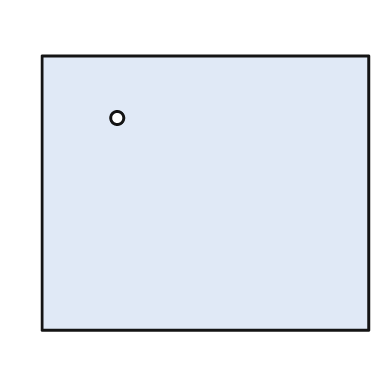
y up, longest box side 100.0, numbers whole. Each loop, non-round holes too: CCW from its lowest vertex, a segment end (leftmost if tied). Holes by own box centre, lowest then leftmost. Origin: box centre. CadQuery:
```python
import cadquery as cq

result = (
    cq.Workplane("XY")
    .moveTo(-50.0, -42.0)
    .lineTo(50.0, -42.0)
    .lineTo(50.0, 42.0)
    .lineTo(-50.0, 42.0)
    .close()
    .moveTo(-27.0, 23.0)
    .circle(2.0)
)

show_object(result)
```